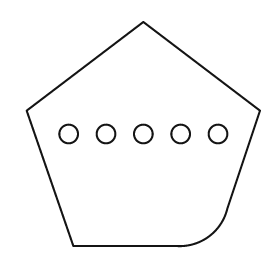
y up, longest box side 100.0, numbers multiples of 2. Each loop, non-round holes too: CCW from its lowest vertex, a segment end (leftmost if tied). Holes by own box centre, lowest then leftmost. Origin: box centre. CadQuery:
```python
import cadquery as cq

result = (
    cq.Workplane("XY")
    .moveTo(-30.0, -48.0)
    .lineTo(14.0, -48.0)
    .threePointArc((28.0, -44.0), (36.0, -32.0))
    .lineTo(50.0, 10.0)
    .lineTo(0.0, 48.0)
    .lineTo(-50.0, 10.0)
    .close()
    .moveTo(-32.0, 0.0)
    .circle(4.0)
    .moveTo(-16.0, 0.0)
    .circle(4.0)
    .moveTo(0.0, 0.0)
    .circle(4.0)
    .moveTo(16.0, 0.0)
    .circle(4.0)
    .moveTo(32.0, 0.0)
    .circle(4.0)
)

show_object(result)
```